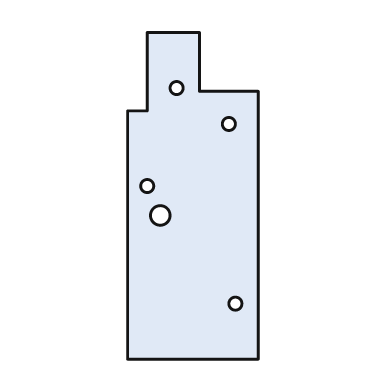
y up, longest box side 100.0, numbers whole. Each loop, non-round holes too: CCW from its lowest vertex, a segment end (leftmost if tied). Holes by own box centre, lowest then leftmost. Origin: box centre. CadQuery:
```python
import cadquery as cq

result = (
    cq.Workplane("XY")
    .moveTo(-20.0, -50.0)
    .lineTo(20.0, -50.0)
    .lineTo(20.0, 32.0)
    .lineTo(2.0, 32.0)
    .lineTo(2.0, 50.0)
    .lineTo(-14.0, 50.0)
    .lineTo(-14.0, 26.0)
    .lineTo(-20.0, 26.0)
    .close()
    .moveTo(13.0, -33.0)
    .circle(2.0)
    .moveTo(-10.0, -6.0)
    .circle(3.0)
    .moveTo(-14.0, 3.0)
    .circle(2.0)
    .moveTo(11.0, 22.0)
    .circle(2.0)
    .moveTo(-5.0, 33.0)
    .circle(2.0)
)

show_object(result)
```